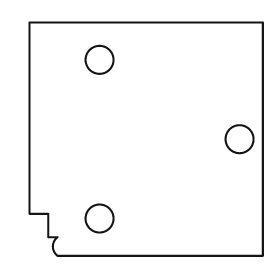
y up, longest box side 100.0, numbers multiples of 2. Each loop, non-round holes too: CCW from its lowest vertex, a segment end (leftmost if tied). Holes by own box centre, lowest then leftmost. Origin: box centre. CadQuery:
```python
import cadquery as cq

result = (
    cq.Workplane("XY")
    .moveTo(-38.0, -50.0)
    .lineTo(50.0, -50.0)
    .lineTo(50.0, 50.0)
    .lineTo(-50.0, 50.0)
    .lineTo(-50.0, -32.0)
    .lineTo(-42.0, -32.0)
    .lineTo(-42.0, -42.0)
    .lineTo(-38.0, -42.0)
    .threePointArc((-40.0, -46.0), (-38.0, -50.0))
    .close()
    .moveTo(-20.0, -34.0)
    .circle(6.0)
    .moveTo(40.0, 0.0)
    .circle(6.0)
    .moveTo(-20.0, 34.0)
    .circle(6.0)
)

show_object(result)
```